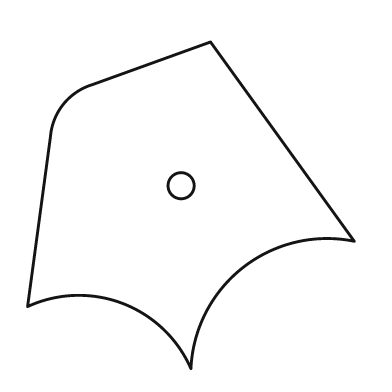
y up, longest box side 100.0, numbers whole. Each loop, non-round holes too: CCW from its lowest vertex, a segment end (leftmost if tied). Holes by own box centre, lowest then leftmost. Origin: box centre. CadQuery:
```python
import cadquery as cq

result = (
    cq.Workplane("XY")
    .moveTo(0.0, -50.0)
    .threePointArc((16.0, -19.0), (50.0, -11.0))
    .lineTo(6.0, 50.0)
    .lineTo(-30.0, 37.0)
    .threePointArc((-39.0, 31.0), (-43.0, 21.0))
    .lineTo(-50.0, -31.0)
    .threePointArc((-21.0, -30.0), (0.0, -50.0))
    .close()
    .moveTo(-3.0, 6.0)
    .circle(4.0)
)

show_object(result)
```